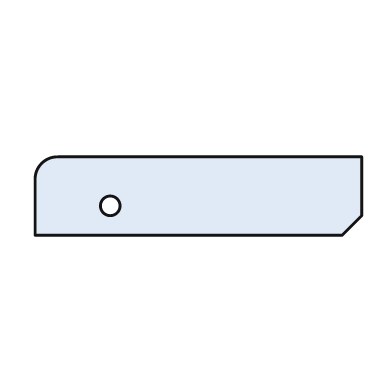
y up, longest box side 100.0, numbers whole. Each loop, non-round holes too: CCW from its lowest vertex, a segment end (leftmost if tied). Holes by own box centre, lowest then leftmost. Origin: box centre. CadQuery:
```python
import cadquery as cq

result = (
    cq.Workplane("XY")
    .moveTo(-50.0, -12.0)
    .lineTo(44.0, -12.0)
    .lineTo(50.0, -6.0)
    .lineTo(50.0, 12.0)
    .lineTo(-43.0, 12.0)
    .threePointArc((-48.0, 10.0), (-50.0, 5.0))
    .close()
    .moveTo(-27.0, -3.0)
    .circle(3.0)
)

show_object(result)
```